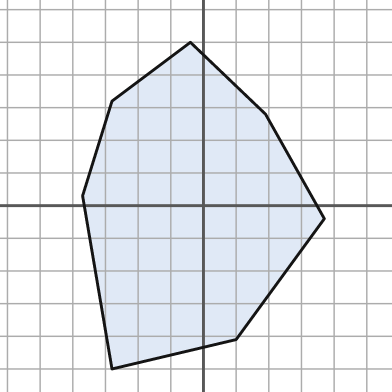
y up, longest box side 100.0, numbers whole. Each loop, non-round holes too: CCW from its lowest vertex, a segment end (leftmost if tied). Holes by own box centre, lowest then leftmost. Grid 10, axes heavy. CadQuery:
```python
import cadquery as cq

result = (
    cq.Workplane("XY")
    .moveTo(-28.0, -50.0)
    .lineTo(10.0, -41.0)
    .lineTo(37.0, -4.0)
    .lineTo(19.0, 28.0)
    .lineTo(-4.0, 50.0)
    .lineTo(-28.0, 32.0)
    .lineTo(-37.0, 3.0)
    .close()
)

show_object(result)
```